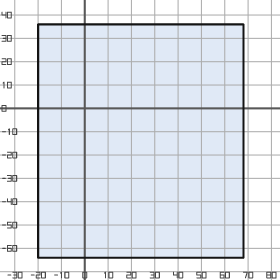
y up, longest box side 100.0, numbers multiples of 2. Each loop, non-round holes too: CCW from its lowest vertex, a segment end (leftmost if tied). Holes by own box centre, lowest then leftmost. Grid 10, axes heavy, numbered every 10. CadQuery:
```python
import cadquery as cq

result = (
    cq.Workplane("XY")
    .moveTo(-20.0, -64.0)
    .lineTo(68.0, -64.0)
    .lineTo(68.0, 36.0)
    .lineTo(-20.0, 36.0)
    .close()
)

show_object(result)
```